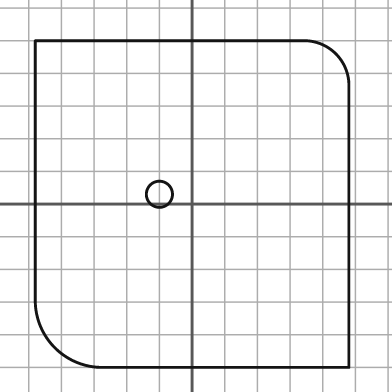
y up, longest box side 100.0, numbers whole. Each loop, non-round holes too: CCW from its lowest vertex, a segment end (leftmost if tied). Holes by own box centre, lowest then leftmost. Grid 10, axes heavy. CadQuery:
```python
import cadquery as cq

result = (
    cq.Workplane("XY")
    .moveTo(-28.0, -50.0)
    .lineTo(48.0, -50.0)
    .lineTo(48.0, 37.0)
    .threePointArc((44.0, 46.0), (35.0, 50.0))
    .lineTo(-48.0, 50.0)
    .lineTo(-48.0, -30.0)
    .threePointArc((-42.0, -44.0), (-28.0, -50.0))
    .close()
    .moveTo(-10.0, 3.0)
    .circle(4.0)
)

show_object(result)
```